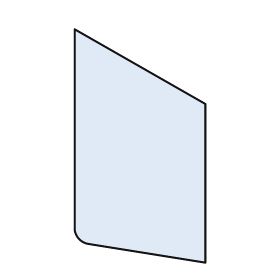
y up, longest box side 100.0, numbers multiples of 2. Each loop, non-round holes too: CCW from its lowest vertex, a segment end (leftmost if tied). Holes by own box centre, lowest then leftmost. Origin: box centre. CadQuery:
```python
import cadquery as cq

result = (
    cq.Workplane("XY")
    .moveTo(28.0, -50.0)
    .lineTo(28.0, 18.0)
    .lineTo(-28.0, 50.0)
    .lineTo(-28.0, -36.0)
    .threePointArc((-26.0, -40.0), (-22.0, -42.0))
    .close()
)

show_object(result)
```